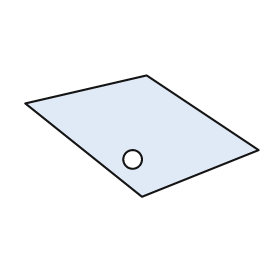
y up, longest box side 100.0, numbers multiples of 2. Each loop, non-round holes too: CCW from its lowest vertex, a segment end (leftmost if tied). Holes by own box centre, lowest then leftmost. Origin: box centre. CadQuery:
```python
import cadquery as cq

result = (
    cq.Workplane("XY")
    .moveTo(0.0, -26.0)
    .lineTo(50.0, -6.0)
    .lineTo(2.0, 26.0)
    .lineTo(-50.0, 14.0)
    .close()
    .moveTo(-4.0, -10.0)
    .circle(4.0)
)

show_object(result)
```